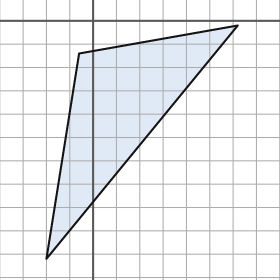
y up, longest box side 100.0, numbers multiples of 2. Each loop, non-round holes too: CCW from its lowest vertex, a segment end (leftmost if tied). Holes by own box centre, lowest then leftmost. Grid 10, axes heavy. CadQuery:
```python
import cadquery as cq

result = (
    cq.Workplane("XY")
    .moveTo(-20.0, -102.0)
    .lineTo(62.0, -2.0)
    .lineTo(-6.0, -14.0)
    .close()
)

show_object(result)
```